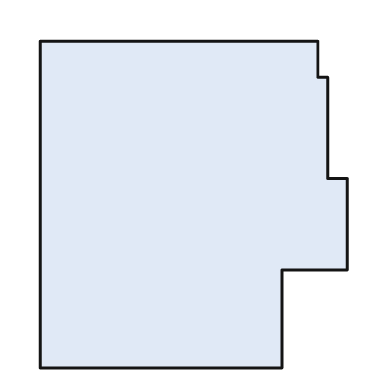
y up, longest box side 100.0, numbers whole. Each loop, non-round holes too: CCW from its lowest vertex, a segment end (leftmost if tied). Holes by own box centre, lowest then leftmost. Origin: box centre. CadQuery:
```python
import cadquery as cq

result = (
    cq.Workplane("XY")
    .moveTo(-47.0, -50.0)
    .lineTo(27.0, -50.0)
    .lineTo(27.0, -20.0)
    .lineTo(47.0, -20.0)
    .lineTo(47.0, 8.0)
    .lineTo(41.0, 8.0)
    .lineTo(41.0, 39.0)
    .lineTo(38.0, 39.0)
    .lineTo(38.0, 50.0)
    .lineTo(-47.0, 50.0)
    .close()
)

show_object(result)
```